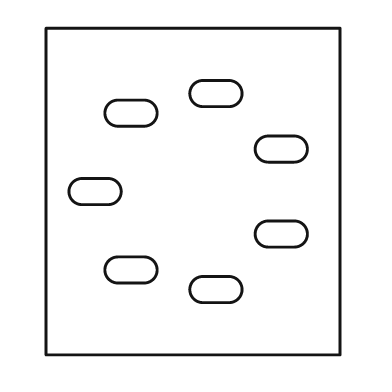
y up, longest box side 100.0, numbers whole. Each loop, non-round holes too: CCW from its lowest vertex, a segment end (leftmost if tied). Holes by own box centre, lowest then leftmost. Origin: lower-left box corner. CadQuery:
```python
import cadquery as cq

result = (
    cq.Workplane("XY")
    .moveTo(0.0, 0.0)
    .lineTo(90.0, 0.0)
    .lineTo(90.0, 100.0)
    .lineTo(0.0, 100.0)
    .close()
    .moveTo(48.0, 16.0)
    .lineTo(56.0, 16.0)
    .threePointArc((60.0, 20.0), (56.0, 24.0))
    .lineTo(48.0, 24.0)
    .threePointArc((44.0, 20.0), (48.0, 16.0))
    .close()
    .moveTo(22.0, 22.0)
    .lineTo(30.0, 22.0)
    .threePointArc((34.0, 26.0), (30.0, 30.0))
    .lineTo(22.0, 30.0)
    .threePointArc((18.0, 26.0), (22.0, 22.0))
    .close()
    .moveTo(68.0, 33.0)
    .lineTo(76.0, 33.0)
    .threePointArc((80.0, 37.0), (76.0, 41.0))
    .lineTo(68.0, 41.0)
    .threePointArc((64.0, 37.0), (68.0, 33.0))
    .close()
    .moveTo(11.0, 46.0)
    .lineTo(19.0, 46.0)
    .threePointArc((23.0, 50.0), (19.0, 54.0))
    .lineTo(11.0, 54.0)
    .threePointArc((7.0, 50.0), (11.0, 46.0))
    .close()
    .moveTo(68.0, 59.0)
    .lineTo(76.0, 59.0)
    .threePointArc((80.0, 63.0), (76.0, 67.0))
    .lineTo(68.0, 67.0)
    .threePointArc((64.0, 63.0), (68.0, 59.0))
    .close()
    .moveTo(22.0, 70.0)
    .lineTo(30.0, 70.0)
    .threePointArc((34.0, 74.0), (30.0, 78.0))
    .lineTo(22.0, 78.0)
    .threePointArc((18.0, 74.0), (22.0, 70.0))
    .close()
    .moveTo(48.0, 76.0)
    .lineTo(56.0, 76.0)
    .threePointArc((60.0, 80.0), (56.0, 84.0))
    .lineTo(48.0, 84.0)
    .threePointArc((44.0, 80.0), (48.0, 76.0))
    .close()
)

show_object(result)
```